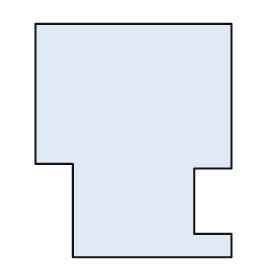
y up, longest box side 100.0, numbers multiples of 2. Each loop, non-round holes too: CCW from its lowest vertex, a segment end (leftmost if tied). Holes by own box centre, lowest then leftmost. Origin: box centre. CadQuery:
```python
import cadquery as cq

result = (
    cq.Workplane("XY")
    .moveTo(-26.0, -50.0)
    .lineTo(42.0, -50.0)
    .lineTo(42.0, -40.0)
    .lineTo(26.0, -40.0)
    .lineTo(26.0, -12.0)
    .lineTo(42.0, -12.0)
    .lineTo(42.0, 50.0)
    .lineTo(-42.0, 50.0)
    .lineTo(-42.0, -10.0)
    .lineTo(-26.0, -10.0)
    .close()
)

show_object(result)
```